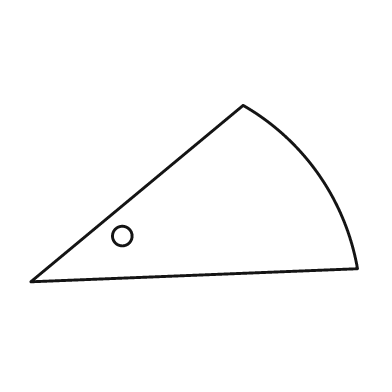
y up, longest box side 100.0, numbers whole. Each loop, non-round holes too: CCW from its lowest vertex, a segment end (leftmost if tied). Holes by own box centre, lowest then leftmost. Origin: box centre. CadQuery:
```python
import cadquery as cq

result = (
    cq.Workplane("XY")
    .moveTo(-50.0, -27.0)
    .lineTo(50.0, -23.0)
    .threePointArc((38.0, 6.0), (15.0, 27.0))
    .close()
    .moveTo(-22.0, -13.0)
    .circle(3.0)
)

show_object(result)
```